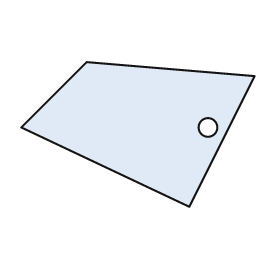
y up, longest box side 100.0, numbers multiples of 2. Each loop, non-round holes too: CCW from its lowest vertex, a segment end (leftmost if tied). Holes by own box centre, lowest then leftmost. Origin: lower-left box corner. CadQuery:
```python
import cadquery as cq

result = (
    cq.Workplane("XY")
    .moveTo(72.0, 0.0)
    .lineTo(100.0, 56.0)
    .lineTo(28.0, 62.0)
    .lineTo(0.0, 34.0)
    .close()
    .moveTo(80.0, 34.0)
    .circle(4.0)
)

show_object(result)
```